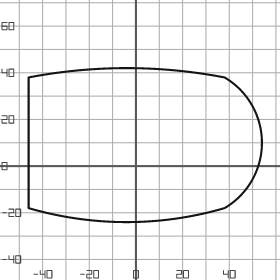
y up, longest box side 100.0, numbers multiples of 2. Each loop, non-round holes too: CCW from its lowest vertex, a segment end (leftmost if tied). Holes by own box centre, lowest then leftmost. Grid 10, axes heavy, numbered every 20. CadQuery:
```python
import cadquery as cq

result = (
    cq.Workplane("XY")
    .moveTo(-46.0, -18.0)
    .threePointArc((-4.0, -24.0), (38.0, -18.0))
    .threePointArc((54.0, 10.0), (38.0, 38.0))
    .threePointArc((-4.0, 42.0), (-46.0, 38.0))
    .close()
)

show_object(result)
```